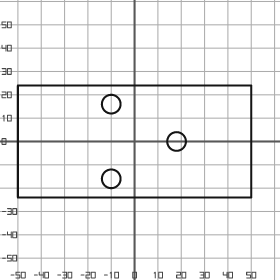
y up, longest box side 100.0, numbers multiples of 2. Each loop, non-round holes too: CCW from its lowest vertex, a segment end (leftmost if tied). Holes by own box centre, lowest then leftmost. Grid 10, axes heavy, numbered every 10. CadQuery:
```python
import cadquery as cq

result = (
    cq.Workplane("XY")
    .moveTo(-50.0, -24.0)
    .lineTo(50.0, -24.0)
    .lineTo(50.0, 24.0)
    .lineTo(-50.0, 24.0)
    .close()
    .moveTo(-10.0, -16.0)
    .circle(4.0)
    .moveTo(18.0, 0.0)
    .circle(4.0)
    .moveTo(-10.0, 16.0)
    .circle(4.0)
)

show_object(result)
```